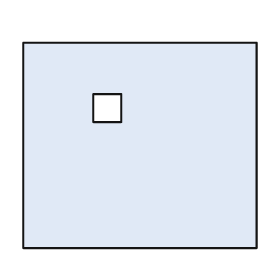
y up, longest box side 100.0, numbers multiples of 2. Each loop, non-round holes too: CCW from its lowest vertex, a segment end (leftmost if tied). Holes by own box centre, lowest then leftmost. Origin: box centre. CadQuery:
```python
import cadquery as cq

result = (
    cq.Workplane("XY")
    .moveTo(-50.0, -44.0)
    .lineTo(50.0, -44.0)
    .lineTo(50.0, 44.0)
    .lineTo(-50.0, 44.0)
    .close()
    .moveTo(-20.0, 10.0)
    .lineTo(-8.0, 10.0)
    .lineTo(-8.0, 22.0)
    .lineTo(-20.0, 22.0)
    .close()
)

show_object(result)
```